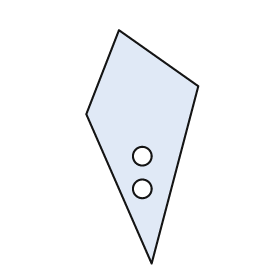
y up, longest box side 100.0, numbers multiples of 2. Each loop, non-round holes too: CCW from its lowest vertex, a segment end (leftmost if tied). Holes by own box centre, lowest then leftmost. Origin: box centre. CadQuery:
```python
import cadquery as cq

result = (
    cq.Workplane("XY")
    .moveTo(4.0, -50.0)
    .lineTo(24.0, 26.0)
    .lineTo(-10.0, 50.0)
    .lineTo(-24.0, 14.0)
    .close()
    .moveTo(0.0, -18.0)
    .circle(4.0)
    .moveTo(0.0, -4.0)
    .circle(4.0)
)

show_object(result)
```